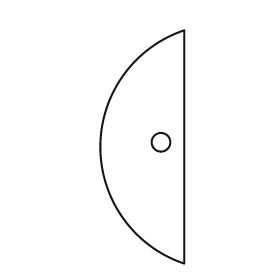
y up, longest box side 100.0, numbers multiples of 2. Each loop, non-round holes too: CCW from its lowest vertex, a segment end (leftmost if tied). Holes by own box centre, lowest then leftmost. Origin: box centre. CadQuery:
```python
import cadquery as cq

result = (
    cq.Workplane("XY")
    .moveTo(18.0, -50.0)
    .lineTo(18.0, 50.0)
    .threePointArc((-18.0, 0.0), (18.0, -50.0))
    .close()
    .moveTo(8.0, 2.0)
    .circle(4.0)
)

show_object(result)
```